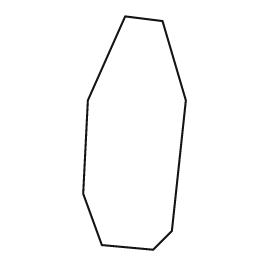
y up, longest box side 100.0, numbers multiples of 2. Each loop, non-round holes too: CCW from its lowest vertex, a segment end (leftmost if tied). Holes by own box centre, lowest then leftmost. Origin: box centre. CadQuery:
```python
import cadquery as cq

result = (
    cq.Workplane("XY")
    .moveTo(8.0, -50.0)
    .lineTo(16.0, -42.0)
    .lineTo(22.0, 14.0)
    .lineTo(12.0, 48.0)
    .lineTo(-4.0, 50.0)
    .lineTo(-20.0, 14.0)
    .lineTo(-22.0, -26.0)
    .lineTo(-14.0, -48.0)
    .close()
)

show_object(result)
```